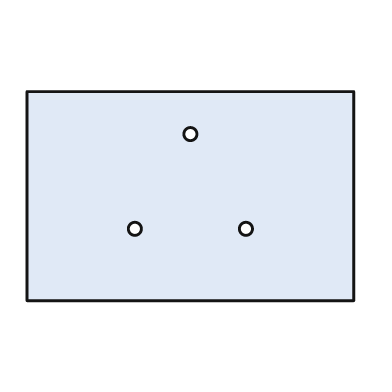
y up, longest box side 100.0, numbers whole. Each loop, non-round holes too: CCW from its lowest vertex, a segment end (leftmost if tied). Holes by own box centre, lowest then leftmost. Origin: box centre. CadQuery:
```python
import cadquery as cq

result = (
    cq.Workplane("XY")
    .moveTo(-50.0, -32.0)
    .lineTo(50.0, -32.0)
    .lineTo(50.0, 32.0)
    .lineTo(-50.0, 32.0)
    .close()
    .moveTo(-17.0, -10.0)
    .circle(2.0)
    .moveTo(17.0, -10.0)
    .circle(2.0)
    .moveTo(0.0, 19.0)
    .circle(2.0)
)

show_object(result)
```